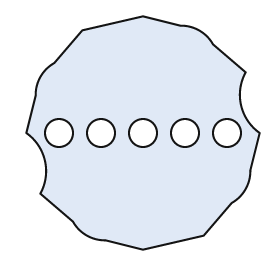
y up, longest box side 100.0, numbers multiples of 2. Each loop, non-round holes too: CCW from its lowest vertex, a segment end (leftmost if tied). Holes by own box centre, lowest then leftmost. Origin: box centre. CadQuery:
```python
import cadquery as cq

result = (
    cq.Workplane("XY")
    .moveTo(0.0, -50.0)
    .lineTo(26.0, -44.0)
    .lineTo(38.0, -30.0)
    .threePointArc((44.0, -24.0), (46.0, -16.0))
    .lineTo(50.0, 0.0)
    .threePointArc((42.0, 12.0), (44.0, 26.0))
    .lineTo(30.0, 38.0)
    .threePointArc((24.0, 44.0), (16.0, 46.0))
    .lineTo(0.0, 50.0)
    .lineTo(-26.0, 44.0)
    .lineTo(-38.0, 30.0)
    .threePointArc((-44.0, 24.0), (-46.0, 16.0))
    .lineTo(-50.0, 0.0)
    .threePointArc((-42.0, -12.0), (-44.0, -26.0))
    .lineTo(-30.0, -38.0)
    .threePointArc((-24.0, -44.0), (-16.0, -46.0))
    .close()
    .moveTo(-36.0, 0.0)
    .circle(6.0)
    .moveTo(-18.0, 0.0)
    .circle(6.0)
    .moveTo(0.0, 0.0)
    .circle(6.0)
    .moveTo(18.0, 0.0)
    .circle(6.0)
    .moveTo(36.0, 0.0)
    .circle(6.0)
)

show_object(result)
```